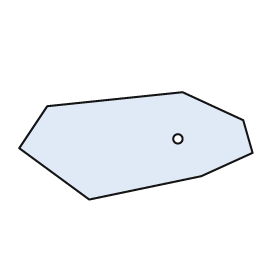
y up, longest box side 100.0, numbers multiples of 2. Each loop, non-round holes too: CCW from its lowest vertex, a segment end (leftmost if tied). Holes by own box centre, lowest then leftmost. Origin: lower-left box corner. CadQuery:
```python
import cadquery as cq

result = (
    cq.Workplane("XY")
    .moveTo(30.0, 0.0)
    .lineTo(78.0, 10.0)
    .lineTo(100.0, 20.0)
    .lineTo(96.0, 34.0)
    .lineTo(70.0, 46.0)
    .lineTo(12.0, 40.0)
    .lineTo(0.0, 22.0)
    .close()
    .moveTo(68.0, 26.0)
    .circle(2.0)
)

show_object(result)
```